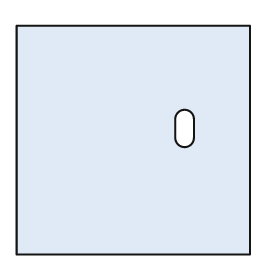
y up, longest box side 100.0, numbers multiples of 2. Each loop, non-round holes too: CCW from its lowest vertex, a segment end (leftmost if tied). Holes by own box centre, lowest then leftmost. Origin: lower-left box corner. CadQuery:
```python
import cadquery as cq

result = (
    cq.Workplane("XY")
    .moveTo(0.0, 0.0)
    .lineTo(100.0, 0.0)
    .lineTo(100.0, 98.0)
    .lineTo(0.0, 98.0)
    .close()
    .moveTo(68.0, 50.0)
    .threePointArc((72.0, 46.0), (76.0, 50.0))
    .lineTo(76.0, 58.0)
    .threePointArc((72.0, 62.0), (68.0, 58.0))
    .close()
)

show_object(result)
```